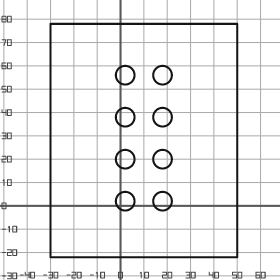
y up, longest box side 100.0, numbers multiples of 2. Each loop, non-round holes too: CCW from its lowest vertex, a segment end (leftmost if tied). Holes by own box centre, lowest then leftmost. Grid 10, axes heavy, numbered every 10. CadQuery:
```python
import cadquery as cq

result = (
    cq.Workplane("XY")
    .moveTo(-30.0, -22.0)
    .lineTo(50.0, -22.0)
    .lineTo(50.0, 78.0)
    .lineTo(-30.0, 78.0)
    .close()
    .moveTo(2.0, 2.0)
    .circle(4.0)
    .moveTo(18.0, 2.0)
    .circle(4.0)
    .moveTo(2.0, 20.0)
    .circle(4.0)
    .moveTo(18.0, 20.0)
    .circle(4.0)
    .moveTo(2.0, 38.0)
    .circle(4.0)
    .moveTo(18.0, 38.0)
    .circle(4.0)
    .moveTo(2.0, 56.0)
    .circle(4.0)
    .moveTo(18.0, 56.0)
    .circle(4.0)
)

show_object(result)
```